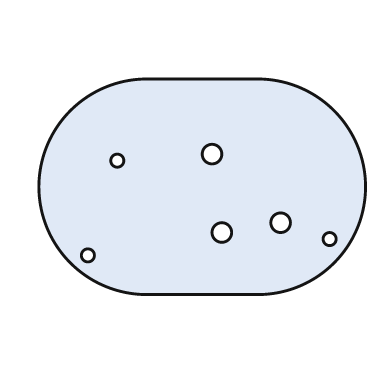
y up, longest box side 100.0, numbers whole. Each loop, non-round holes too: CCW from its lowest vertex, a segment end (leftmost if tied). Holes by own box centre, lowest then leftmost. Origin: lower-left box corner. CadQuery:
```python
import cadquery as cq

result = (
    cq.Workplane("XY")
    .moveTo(33.0, 0.0)
    .lineTo(67.0, 0.0)
    .threePointArc((100.0, 33.0), (67.0, 66.0))
    .lineTo(33.0, 66.0)
    .threePointArc((0.0, 33.0), (33.0, 0.0))
    .close()
    .moveTo(15.0, 12.0)
    .circle(2.0)
    .moveTo(89.0, 17.0)
    .circle(2.0)
    .moveTo(56.0, 19.0)
    .circle(3.0)
    .moveTo(74.0, 22.0)
    .circle(3.0)
    .moveTo(24.0, 41.0)
    .circle(2.0)
    .moveTo(53.0, 43.0)
    .circle(3.0)
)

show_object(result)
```